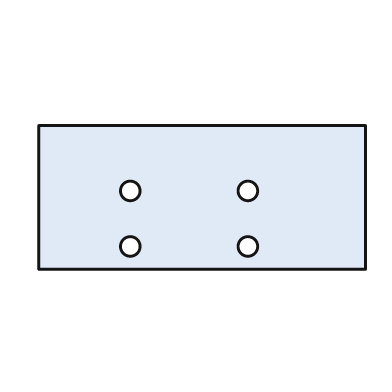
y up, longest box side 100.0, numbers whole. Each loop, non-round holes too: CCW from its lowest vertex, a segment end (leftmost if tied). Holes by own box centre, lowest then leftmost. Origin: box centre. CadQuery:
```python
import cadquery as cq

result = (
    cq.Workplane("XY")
    .moveTo(-50.0, -22.0)
    .lineTo(50.0, -22.0)
    .lineTo(50.0, 22.0)
    .lineTo(-50.0, 22.0)
    .close()
    .moveTo(-22.0, -15.0)
    .circle(3.0)
    .moveTo(14.0, -15.0)
    .circle(3.0)
    .moveTo(-22.0, 2.0)
    .circle(3.0)
    .moveTo(14.0, 2.0)
    .circle(3.0)
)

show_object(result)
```